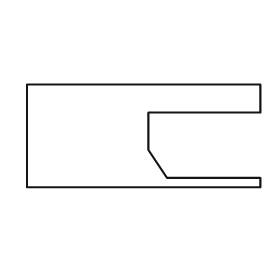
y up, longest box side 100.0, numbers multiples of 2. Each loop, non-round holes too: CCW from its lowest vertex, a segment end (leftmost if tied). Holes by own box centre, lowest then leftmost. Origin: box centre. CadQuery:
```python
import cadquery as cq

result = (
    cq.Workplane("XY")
    .moveTo(-50.0, -22.0)
    .lineTo(50.0, -22.0)
    .lineTo(50.0, -18.0)
    .lineTo(10.0, -18.0)
    .lineTo(2.0, -6.0)
    .lineTo(2.0, 10.0)
    .lineTo(50.0, 10.0)
    .lineTo(50.0, 22.0)
    .lineTo(-50.0, 22.0)
    .close()
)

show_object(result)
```